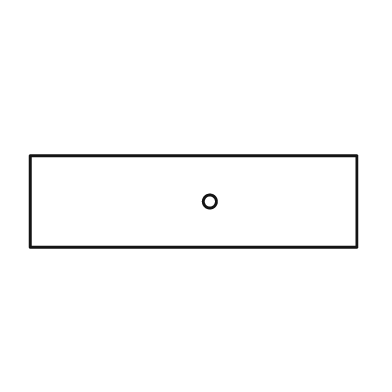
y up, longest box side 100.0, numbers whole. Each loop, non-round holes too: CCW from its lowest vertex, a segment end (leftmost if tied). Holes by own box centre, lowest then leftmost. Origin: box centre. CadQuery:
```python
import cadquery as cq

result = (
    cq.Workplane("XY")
    .moveTo(-50.0, -14.0)
    .lineTo(50.0, -14.0)
    .lineTo(50.0, 14.0)
    .lineTo(-50.0, 14.0)
    .close()
    .moveTo(5.0, 0.0)
    .circle(2.0)
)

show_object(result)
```